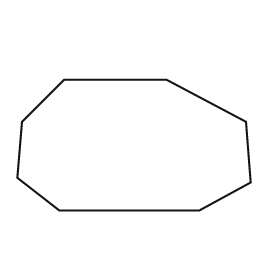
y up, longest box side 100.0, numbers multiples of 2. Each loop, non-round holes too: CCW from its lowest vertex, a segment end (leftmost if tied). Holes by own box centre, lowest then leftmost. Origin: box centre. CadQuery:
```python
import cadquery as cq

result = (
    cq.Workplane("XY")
    .moveTo(-32.0, -28.0)
    .lineTo(28.0, -28.0)
    .lineTo(50.0, -16.0)
    .lineTo(48.0, 10.0)
    .lineTo(14.0, 28.0)
    .lineTo(-30.0, 28.0)
    .lineTo(-48.0, 10.0)
    .lineTo(-50.0, -14.0)
    .close()
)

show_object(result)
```